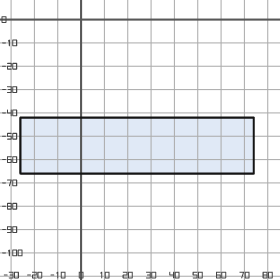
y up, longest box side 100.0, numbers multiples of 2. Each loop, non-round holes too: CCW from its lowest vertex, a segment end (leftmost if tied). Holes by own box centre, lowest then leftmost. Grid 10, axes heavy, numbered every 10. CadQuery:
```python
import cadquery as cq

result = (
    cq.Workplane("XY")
    .moveTo(-26.0, -66.0)
    .lineTo(74.0, -66.0)
    .lineTo(74.0, -42.0)
    .lineTo(-26.0, -42.0)
    .close()
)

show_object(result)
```